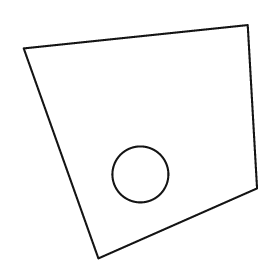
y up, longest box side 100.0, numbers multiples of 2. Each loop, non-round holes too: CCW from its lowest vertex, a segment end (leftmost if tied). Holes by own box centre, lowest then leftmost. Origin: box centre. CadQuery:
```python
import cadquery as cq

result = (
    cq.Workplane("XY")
    .moveTo(-18.0, -50.0)
    .lineTo(50.0, -20.0)
    .lineTo(46.0, 50.0)
    .lineTo(-50.0, 40.0)
    .close()
    .moveTo(0.0, -14.0)
    .circle(12.0)
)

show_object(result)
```